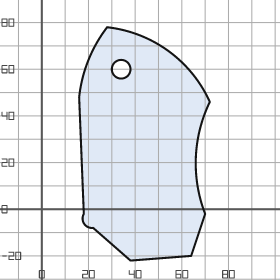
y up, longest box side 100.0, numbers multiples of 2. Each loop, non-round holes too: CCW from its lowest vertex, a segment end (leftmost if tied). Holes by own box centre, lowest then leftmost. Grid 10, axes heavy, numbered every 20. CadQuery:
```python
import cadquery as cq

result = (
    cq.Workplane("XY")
    .moveTo(38.0, -22.0)
    .lineTo(64.0, -20.0)
    .lineTo(70.0, -2.0)
    .threePointArc((66.0, 22.0), (72.0, 46.0))
    .threePointArc((54.0, 68.0), (28.0, 78.0))
    .threePointArc((20.0, 64.0), (16.0, 48.0))
    .lineTo(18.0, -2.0)
    .threePointArc((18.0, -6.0), (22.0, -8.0))
    .close()
    .moveTo(34.0, 60.0)
    .circle(4.0)
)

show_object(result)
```